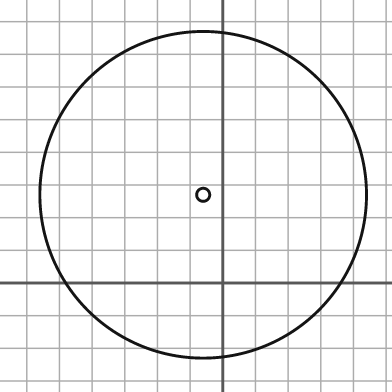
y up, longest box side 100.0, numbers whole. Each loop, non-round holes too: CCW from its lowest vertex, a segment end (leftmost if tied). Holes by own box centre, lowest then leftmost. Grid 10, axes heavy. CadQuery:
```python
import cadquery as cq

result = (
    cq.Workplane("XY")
    .moveTo(-6.0, 27.0)
    .circle(50.0)
    .moveTo(-6.0, 27.0)
    .circle(2.0)
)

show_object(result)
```